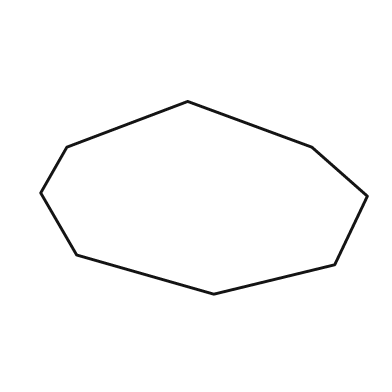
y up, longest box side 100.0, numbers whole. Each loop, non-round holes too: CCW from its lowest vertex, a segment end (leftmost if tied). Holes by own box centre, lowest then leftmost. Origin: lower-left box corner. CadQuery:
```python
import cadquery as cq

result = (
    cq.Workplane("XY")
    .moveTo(53.0, 0.0)
    .lineTo(90.0, 9.0)
    .lineTo(100.0, 30.0)
    .lineTo(83.0, 45.0)
    .lineTo(45.0, 59.0)
    .lineTo(8.0, 45.0)
    .lineTo(0.0, 31.0)
    .lineTo(11.0, 12.0)
    .close()
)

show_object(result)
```